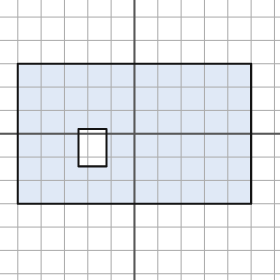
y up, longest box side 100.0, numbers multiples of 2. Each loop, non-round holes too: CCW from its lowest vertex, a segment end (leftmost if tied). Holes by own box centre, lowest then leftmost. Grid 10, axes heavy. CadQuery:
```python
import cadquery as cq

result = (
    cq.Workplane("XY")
    .moveTo(-50.0, -30.0)
    .lineTo(50.0, -30.0)
    .lineTo(50.0, 30.0)
    .lineTo(-50.0, 30.0)
    .close()
    .moveTo(-24.0, -14.0)
    .lineTo(-12.0, -14.0)
    .lineTo(-12.0, 2.0)
    .lineTo(-24.0, 2.0)
    .close()
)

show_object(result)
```